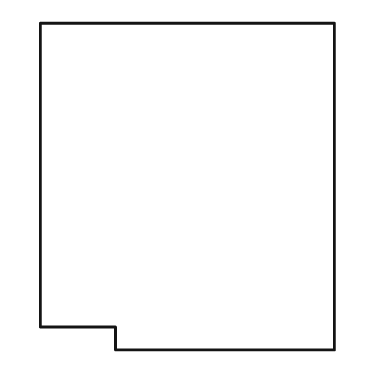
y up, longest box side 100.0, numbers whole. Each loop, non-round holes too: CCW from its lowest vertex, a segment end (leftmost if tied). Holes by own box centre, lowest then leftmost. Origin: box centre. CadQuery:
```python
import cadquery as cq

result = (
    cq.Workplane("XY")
    .moveTo(-22.0, -50.0)
    .lineTo(45.0, -50.0)
    .lineTo(45.0, 50.0)
    .lineTo(-45.0, 50.0)
    .lineTo(-45.0, -43.0)
    .lineTo(-22.0, -43.0)
    .close()
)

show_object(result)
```